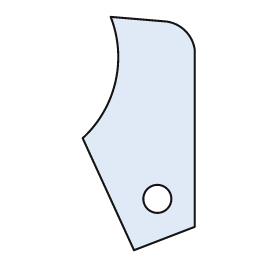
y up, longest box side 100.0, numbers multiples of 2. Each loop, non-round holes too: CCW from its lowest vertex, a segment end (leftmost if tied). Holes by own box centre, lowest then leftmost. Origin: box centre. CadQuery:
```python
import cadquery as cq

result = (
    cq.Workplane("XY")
    .moveTo(-2.0, -50.0)
    .lineTo(24.0, -40.0)
    .lineTo(24.0, 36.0)
    .threePointArc((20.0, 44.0), (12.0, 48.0))
    .lineTo(-12.0, 50.0)
    .threePointArc((-10.0, 22.0), (-24.0, -2.0))
    .close()
    .moveTo(8.0, -28.0)
    .circle(6.0)
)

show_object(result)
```